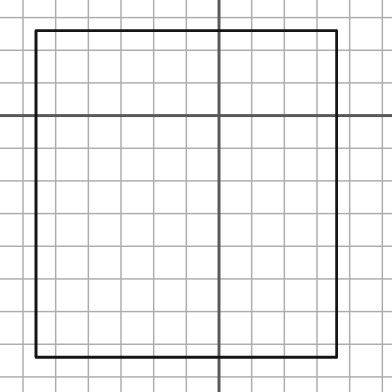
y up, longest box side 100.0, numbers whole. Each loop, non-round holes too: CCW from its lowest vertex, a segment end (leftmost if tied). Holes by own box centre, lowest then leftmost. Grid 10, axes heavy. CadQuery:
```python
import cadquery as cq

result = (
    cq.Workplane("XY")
    .moveTo(-56.0, -74.0)
    .lineTo(36.0, -74.0)
    .lineTo(36.0, 26.0)
    .lineTo(-56.0, 26.0)
    .close()
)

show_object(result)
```